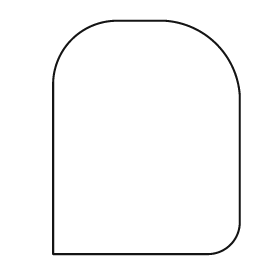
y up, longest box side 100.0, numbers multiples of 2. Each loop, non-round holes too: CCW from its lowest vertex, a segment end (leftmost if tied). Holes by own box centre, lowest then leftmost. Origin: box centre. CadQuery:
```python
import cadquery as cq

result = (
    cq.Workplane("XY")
    .moveTo(-40.0, -50.0)
    .lineTo(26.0, -50.0)
    .threePointArc((36.0, -46.0), (40.0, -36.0))
    .lineTo(40.0, 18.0)
    .threePointArc((30.0, 40.0), (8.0, 50.0))
    .lineTo(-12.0, 50.0)
    .threePointArc((-32.0, 42.0), (-40.0, 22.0))
    .close()
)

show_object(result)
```